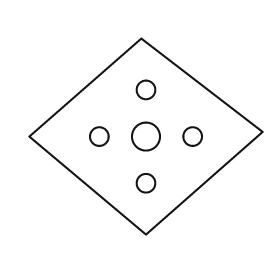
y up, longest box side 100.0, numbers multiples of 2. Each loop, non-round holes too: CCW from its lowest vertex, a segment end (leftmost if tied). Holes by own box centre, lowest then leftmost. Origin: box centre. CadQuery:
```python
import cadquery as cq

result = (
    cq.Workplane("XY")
    .moveTo(0.0, -42.0)
    .lineTo(50.0, 2.0)
    .lineTo(-2.0, 42.0)
    .lineTo(-50.0, 0.0)
    .close()
    .moveTo(0.0, -20.0)
    .circle(4.0)
    .moveTo(-20.0, 0.0)
    .circle(4.0)
    .moveTo(0.0, 0.0)
    .circle(6.0)
    .moveTo(20.0, 0.0)
    .circle(4.0)
    .moveTo(0.0, 20.0)
    .circle(4.0)
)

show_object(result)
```